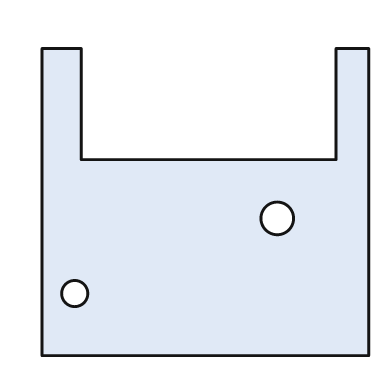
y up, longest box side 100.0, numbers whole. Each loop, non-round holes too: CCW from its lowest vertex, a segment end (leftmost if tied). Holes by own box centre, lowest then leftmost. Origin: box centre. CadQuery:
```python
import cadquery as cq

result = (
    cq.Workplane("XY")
    .moveTo(-50.0, -47.0)
    .lineTo(50.0, -47.0)
    .lineTo(50.0, 47.0)
    .lineTo(40.0, 47.0)
    .lineTo(40.0, 13.0)
    .lineTo(-38.0, 13.0)
    .lineTo(-38.0, 47.0)
    .lineTo(-50.0, 47.0)
    .close()
    .moveTo(-40.0, -28.0)
    .circle(4.0)
    .moveTo(22.0, -5.0)
    .circle(5.0)
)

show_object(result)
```